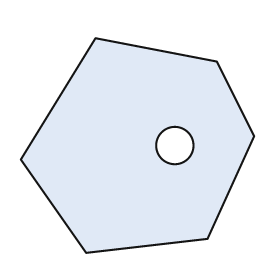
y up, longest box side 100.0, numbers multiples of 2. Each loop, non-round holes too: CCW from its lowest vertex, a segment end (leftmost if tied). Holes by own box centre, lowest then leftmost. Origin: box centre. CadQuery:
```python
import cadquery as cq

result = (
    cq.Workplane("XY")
    .moveTo(-22.0, -46.0)
    .lineTo(30.0, -40.0)
    .lineTo(50.0, 4.0)
    .lineTo(34.0, 36.0)
    .lineTo(-18.0, 46.0)
    .lineTo(-50.0, -6.0)
    .close()
    .moveTo(16.0, 0.0)
    .circle(8.0)
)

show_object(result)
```